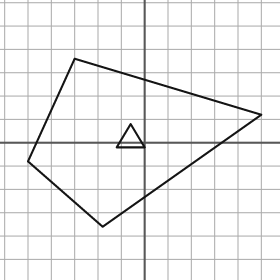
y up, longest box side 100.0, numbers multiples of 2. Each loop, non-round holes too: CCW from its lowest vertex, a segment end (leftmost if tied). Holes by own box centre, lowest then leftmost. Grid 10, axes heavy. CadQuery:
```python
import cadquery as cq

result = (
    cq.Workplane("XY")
    .moveTo(-18.0, -36.0)
    .lineTo(50.0, 12.0)
    .lineTo(-30.0, 36.0)
    .lineTo(-50.0, -8.0)
    .close()
    .moveTo(-12.0, -2.0)
    .lineTo(0.0, -2.0)
    .lineTo(-6.0, 8.0)
    .close()
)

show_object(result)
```